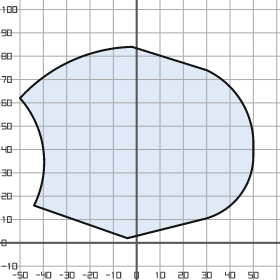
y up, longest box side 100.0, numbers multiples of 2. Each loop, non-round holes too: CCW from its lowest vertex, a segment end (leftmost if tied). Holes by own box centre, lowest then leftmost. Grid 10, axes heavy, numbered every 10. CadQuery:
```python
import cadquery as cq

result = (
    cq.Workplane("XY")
    .moveTo(-4.0, 2.0)
    .lineTo(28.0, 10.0)
    .threePointArc((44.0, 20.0), (50.0, 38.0))
    .lineTo(50.0, 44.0)
    .threePointArc((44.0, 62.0), (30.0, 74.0))
    .lineTo(-2.0, 84.0)
    .threePointArc((-28.0, 78.0), (-50.0, 62.0))
    .threePointArc((-40.0, 40.0), (-44.0, 16.0))
    .close()
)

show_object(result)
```